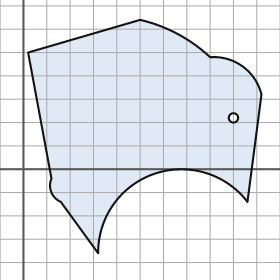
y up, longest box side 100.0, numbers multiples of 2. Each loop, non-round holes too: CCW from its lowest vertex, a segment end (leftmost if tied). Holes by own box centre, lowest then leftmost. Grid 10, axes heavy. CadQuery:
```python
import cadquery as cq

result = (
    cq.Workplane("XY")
    .moveTo(32.0, -36.0)
    .threePointArc((56.0, -2.0), (96.0, -14.0))
    .lineTo(102.0, 32.0)
    .threePointArc((94.0, 44.0), (80.0, 48.0))
    .threePointArc((66.0, 58.0), (50.0, 64.0))
    .lineTo(2.0, 50.0)
    .lineTo(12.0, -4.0)
    .threePointArc((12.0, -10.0), (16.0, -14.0))
    .close()
    .moveTo(90.0, 22.0)
    .circle(2.0)
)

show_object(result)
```